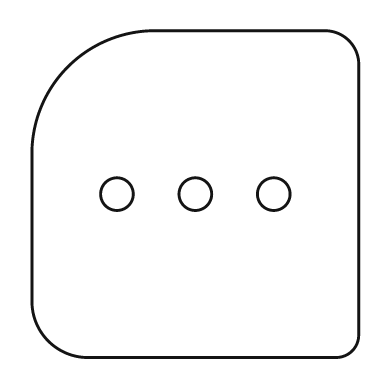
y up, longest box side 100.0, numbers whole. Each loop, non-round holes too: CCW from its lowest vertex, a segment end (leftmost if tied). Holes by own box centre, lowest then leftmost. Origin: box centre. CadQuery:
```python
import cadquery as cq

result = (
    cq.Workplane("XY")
    .moveTo(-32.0, -50.0)
    .lineTo(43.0, -50.0)
    .threePointArc((48.0, -48.0), (50.0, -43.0))
    .lineTo(50.0, 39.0)
    .threePointArc((47.0, 47.0), (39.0, 50.0))
    .lineTo(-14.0, 50.0)
    .threePointArc((-39.0, 39.0), (-50.0, 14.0))
    .lineTo(-50.0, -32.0)
    .threePointArc((-45.0, -45.0), (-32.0, -50.0))
    .close()
    .moveTo(-24.0, 0.0)
    .circle(5.0)
    .moveTo(0.0, 0.0)
    .circle(5.0)
    .moveTo(24.0, 0.0)
    .circle(5.0)
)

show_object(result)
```